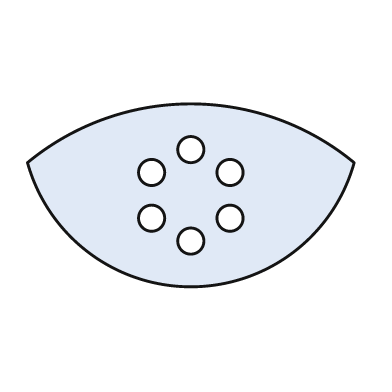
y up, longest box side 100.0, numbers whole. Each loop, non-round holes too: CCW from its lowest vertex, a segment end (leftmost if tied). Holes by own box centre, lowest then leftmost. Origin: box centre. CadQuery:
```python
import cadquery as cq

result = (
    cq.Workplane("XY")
    .moveTo(-50.0, 10.0)
    .threePointArc((0.0, -28.0), (50.0, 10.0))
    .threePointArc((0.0, 28.0), (-50.0, 10.0))
    .close()
    .moveTo(0.0, -14.0)
    .circle(4.0)
    .moveTo(-12.0, -7.0)
    .circle(4.0)
    .moveTo(12.0, -7.0)
    .circle(4.0)
    .moveTo(-12.0, 7.0)
    .circle(4.0)
    .moveTo(12.0, 7.0)
    .circle(4.0)
    .moveTo(0.0, 14.0)
    .circle(4.0)
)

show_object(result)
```